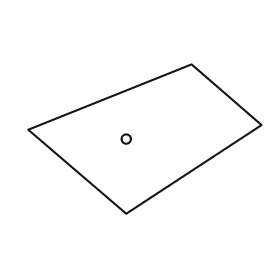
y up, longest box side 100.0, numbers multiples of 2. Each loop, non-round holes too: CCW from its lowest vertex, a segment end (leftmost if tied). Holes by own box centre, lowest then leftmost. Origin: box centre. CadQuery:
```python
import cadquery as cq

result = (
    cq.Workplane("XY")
    .moveTo(-8.0, -32.0)
    .lineTo(50.0, 6.0)
    .lineTo(20.0, 32.0)
    .lineTo(-50.0, 4.0)
    .close()
    .moveTo(-8.0, 0.0)
    .circle(2.0)
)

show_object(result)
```